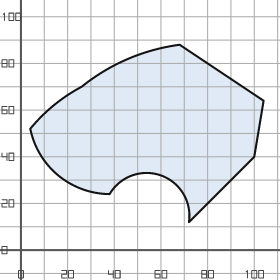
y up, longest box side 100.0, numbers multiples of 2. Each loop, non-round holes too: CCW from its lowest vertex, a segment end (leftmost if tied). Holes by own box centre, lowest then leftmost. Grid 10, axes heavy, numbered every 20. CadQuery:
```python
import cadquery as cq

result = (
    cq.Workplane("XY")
    .moveTo(72.0, 12.0)
    .lineTo(100.0, 40.0)
    .lineTo(104.0, 64.0)
    .lineTo(68.0, 88.0)
    .threePointArc((46.0, 82.0), (26.0, 70.0))
    .threePointArc((14.0, 62.0), (4.0, 52.0))
    .threePointArc((16.0, 32.0), (38.0, 24.0))
    .threePointArc((60.0, 32.0), (72.0, 12.0))
    .close()
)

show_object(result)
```